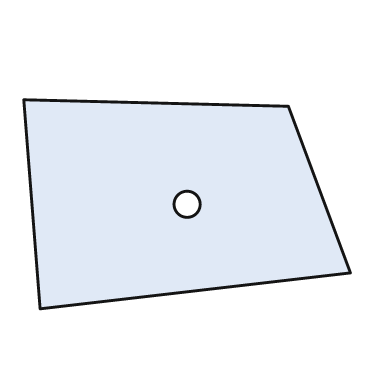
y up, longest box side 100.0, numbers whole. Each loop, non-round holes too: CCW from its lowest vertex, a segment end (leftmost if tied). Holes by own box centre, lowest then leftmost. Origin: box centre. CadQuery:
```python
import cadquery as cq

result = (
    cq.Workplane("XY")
    .moveTo(-45.0, -32.0)
    .lineTo(50.0, -21.0)
    .lineTo(31.0, 30.0)
    .lineTo(-50.0, 32.0)
    .close()
    .moveTo(0.0, 0.0)
    .circle(4.0)
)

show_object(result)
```